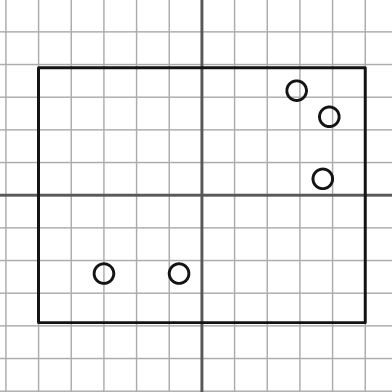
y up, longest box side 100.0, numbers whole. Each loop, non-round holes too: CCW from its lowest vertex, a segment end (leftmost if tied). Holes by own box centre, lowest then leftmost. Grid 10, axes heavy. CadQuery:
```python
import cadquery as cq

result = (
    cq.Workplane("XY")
    .moveTo(-50.0, -39.0)
    .lineTo(50.0, -39.0)
    .lineTo(50.0, 39.0)
    .lineTo(-50.0, 39.0)
    .close()
    .moveTo(-30.0, -24.0)
    .circle(3.0)
    .moveTo(-7.0, -24.0)
    .circle(3.0)
    .moveTo(37.0, 5.0)
    .circle(3.0)
    .moveTo(39.0, 24.0)
    .circle(3.0)
    .moveTo(29.0, 32.0)
    .circle(3.0)
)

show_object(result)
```